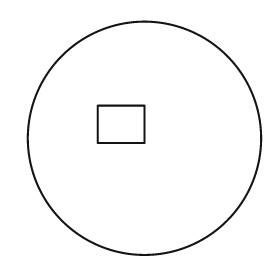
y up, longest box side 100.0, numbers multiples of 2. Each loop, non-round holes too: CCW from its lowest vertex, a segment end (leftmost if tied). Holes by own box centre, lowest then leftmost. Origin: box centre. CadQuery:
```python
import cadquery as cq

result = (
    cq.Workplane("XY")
    .moveTo(0.0, 0.0)
    .circle(50.0)
    .moveTo(-20.0, -2.0)
    .lineTo(0.0, -2.0)
    .lineTo(0.0, 14.0)
    .lineTo(-20.0, 14.0)
    .close()
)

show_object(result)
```